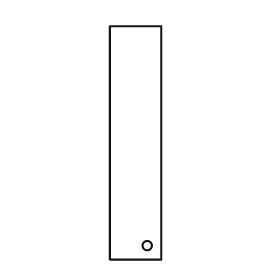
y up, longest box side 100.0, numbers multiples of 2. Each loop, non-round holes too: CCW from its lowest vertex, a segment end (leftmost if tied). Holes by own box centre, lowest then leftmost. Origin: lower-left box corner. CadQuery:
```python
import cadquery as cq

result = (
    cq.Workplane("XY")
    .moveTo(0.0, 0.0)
    .lineTo(22.0, 0.0)
    .lineTo(22.0, 100.0)
    .lineTo(0.0, 100.0)
    .close()
    .moveTo(16.0, 6.0)
    .circle(2.0)
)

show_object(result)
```